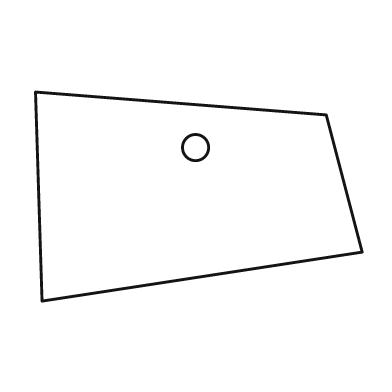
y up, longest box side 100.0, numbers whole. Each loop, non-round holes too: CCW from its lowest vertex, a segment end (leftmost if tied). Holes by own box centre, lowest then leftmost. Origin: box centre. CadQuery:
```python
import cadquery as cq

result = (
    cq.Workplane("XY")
    .moveTo(-48.0, -32.0)
    .lineTo(50.0, -17.0)
    .lineTo(39.0, 25.0)
    .lineTo(-50.0, 32.0)
    .close()
    .moveTo(-1.0, 15.0)
    .circle(4.0)
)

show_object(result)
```